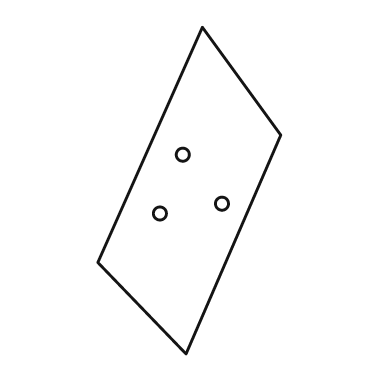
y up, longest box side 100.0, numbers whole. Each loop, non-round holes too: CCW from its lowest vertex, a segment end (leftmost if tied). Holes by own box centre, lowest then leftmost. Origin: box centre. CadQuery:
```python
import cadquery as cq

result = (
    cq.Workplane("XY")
    .moveTo(-1.0, -50.0)
    .lineTo(28.0, 17.0)
    .lineTo(4.0, 50.0)
    .lineTo(-28.0, -22.0)
    .close()
    .moveTo(-9.0, -7.0)
    .circle(2.0)
    .moveTo(10.0, -4.0)
    .circle(2.0)
    .moveTo(-2.0, 11.0)
    .circle(2.0)
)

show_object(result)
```